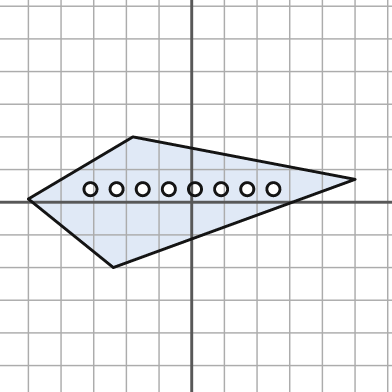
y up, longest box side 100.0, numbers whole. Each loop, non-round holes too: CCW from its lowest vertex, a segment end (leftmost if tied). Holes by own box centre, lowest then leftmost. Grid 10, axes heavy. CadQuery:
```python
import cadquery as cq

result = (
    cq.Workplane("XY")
    .moveTo(-24.0, -20.0)
    .lineTo(50.0, 7.0)
    .lineTo(-18.0, 20.0)
    .lineTo(-50.0, 1.0)
    .close()
    .moveTo(-31.0, 4.0)
    .circle(2.0)
    .moveTo(-23.0, 4.0)
    .circle(2.0)
    .moveTo(-15.0, 4.0)
    .circle(2.0)
    .moveTo(-7.0, 4.0)
    .circle(2.0)
    .moveTo(1.0, 4.0)
    .circle(2.0)
    .moveTo(9.0, 4.0)
    .circle(2.0)
    .moveTo(17.0, 4.0)
    .circle(2.0)
    .moveTo(25.0, 4.0)
    .circle(2.0)
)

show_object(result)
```